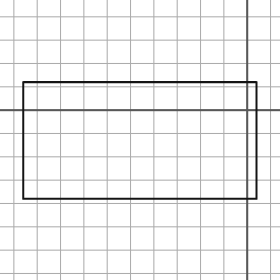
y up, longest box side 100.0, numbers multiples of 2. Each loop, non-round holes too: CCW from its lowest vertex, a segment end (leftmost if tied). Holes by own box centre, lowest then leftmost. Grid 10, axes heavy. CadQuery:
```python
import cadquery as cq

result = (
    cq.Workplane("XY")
    .moveTo(-96.0, -38.0)
    .lineTo(4.0, -38.0)
    .lineTo(4.0, 12.0)
    .lineTo(-96.0, 12.0)
    .close()
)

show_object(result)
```